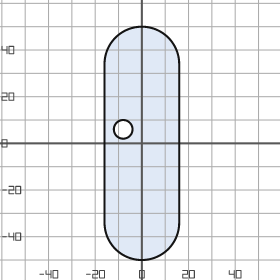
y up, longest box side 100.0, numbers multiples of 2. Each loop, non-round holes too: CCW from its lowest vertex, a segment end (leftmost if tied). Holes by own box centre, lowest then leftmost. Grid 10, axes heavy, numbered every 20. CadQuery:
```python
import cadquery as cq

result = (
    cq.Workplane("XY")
    .moveTo(-16.0, -34.0)
    .threePointArc((0.0, -50.0), (16.0, -34.0))
    .lineTo(16.0, 34.0)
    .threePointArc((0.0, 50.0), (-16.0, 34.0))
    .close()
    .moveTo(-8.0, 6.0)
    .circle(4.0)
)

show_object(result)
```